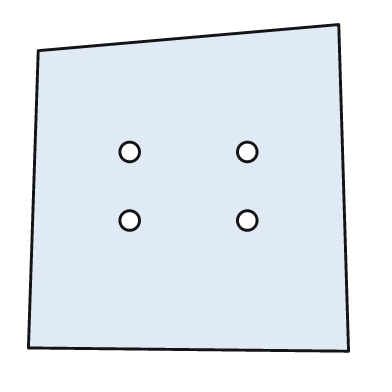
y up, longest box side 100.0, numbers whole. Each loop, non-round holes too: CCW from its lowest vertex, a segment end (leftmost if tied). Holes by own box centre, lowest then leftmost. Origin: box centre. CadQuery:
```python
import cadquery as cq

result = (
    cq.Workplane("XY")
    .moveTo(49.0, -50.0)
    .lineTo(46.0, 50.0)
    .lineTo(-46.0, 42.0)
    .lineTo(-49.0, -49.0)
    .close()
    .moveTo(-18.0, -10.0)
    .circle(3.0)
    .moveTo(18.0, -10.0)
    .circle(3.0)
    .moveTo(-18.0, 11.0)
    .circle(3.0)
    .moveTo(18.0, 11.0)
    .circle(3.0)
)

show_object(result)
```